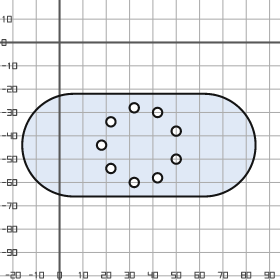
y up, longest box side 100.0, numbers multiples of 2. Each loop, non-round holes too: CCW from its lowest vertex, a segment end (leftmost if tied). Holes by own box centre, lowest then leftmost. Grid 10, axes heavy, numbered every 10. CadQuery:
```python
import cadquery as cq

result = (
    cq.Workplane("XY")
    .moveTo(6.0, -66.0)
    .lineTo(62.0, -66.0)
    .threePointArc((84.0, -44.0), (62.0, -22.0))
    .lineTo(6.0, -22.0)
    .threePointArc((-16.0, -44.0), (6.0, -66.0))
    .close()
    .moveTo(32.0, -60.0)
    .circle(2.0)
    .moveTo(42.0, -58.0)
    .circle(2.0)
    .moveTo(22.0, -54.0)
    .circle(2.0)
    .moveTo(50.0, -50.0)
    .circle(2.0)
    .moveTo(18.0, -44.0)
    .circle(2.0)
    .moveTo(50.0, -38.0)
    .circle(2.0)
    .moveTo(22.0, -34.0)
    .circle(2.0)
    .moveTo(42.0, -30.0)
    .circle(2.0)
    .moveTo(32.0, -28.0)
    .circle(2.0)
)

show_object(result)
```